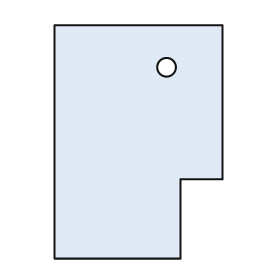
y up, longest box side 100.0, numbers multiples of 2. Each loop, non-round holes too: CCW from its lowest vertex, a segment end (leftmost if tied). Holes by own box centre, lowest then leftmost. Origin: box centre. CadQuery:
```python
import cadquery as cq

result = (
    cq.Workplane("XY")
    .moveTo(-36.0, -50.0)
    .lineTo(18.0, -50.0)
    .lineTo(18.0, -16.0)
    .lineTo(36.0, -16.0)
    .lineTo(36.0, 50.0)
    .lineTo(-36.0, 50.0)
    .close()
    .moveTo(12.0, 32.0)
    .circle(4.0)
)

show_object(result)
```